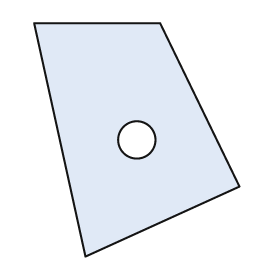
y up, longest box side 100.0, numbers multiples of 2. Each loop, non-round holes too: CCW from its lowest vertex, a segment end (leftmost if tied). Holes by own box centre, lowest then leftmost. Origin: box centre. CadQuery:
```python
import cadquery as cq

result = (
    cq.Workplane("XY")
    .moveTo(-22.0, -50.0)
    .lineTo(44.0, -20.0)
    .lineTo(10.0, 50.0)
    .lineTo(-44.0, 50.0)
    .close()
    .moveTo(0.0, 0.0)
    .circle(8.0)
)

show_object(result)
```